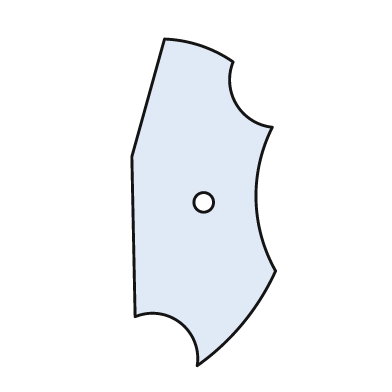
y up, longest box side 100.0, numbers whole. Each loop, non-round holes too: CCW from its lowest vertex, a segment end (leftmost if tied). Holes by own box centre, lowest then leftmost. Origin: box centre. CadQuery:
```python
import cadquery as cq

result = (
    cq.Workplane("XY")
    .moveTo(-2.0, -50.0)
    .threePointArc((12.0, -37.0), (22.0, -21.0))
    .threePointArc((16.0, 1.0), (21.0, 23.0))
    .threePointArc((10.0, 30.0), (9.0, 43.0))
    .threePointArc((-1.0, 48.0), (-12.0, 50.0))
    .lineTo(-22.0, 14.0)
    .lineTo(-21.0, -35.0)
    .threePointArc((-7.0, -37.0), (-2.0, -50.0))
    .close()
    .moveTo(0.0, 0.0)
    .circle(3.0)
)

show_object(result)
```